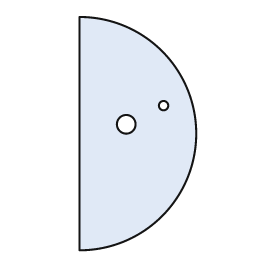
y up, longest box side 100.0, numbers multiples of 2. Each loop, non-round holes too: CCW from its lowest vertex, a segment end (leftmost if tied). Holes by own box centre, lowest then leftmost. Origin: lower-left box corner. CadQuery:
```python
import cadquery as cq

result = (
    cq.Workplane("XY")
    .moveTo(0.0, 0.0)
    .threePointArc((50.0, 50.0), (0.0, 100.0))
    .close()
    .moveTo(20.0, 54.0)
    .circle(4.0)
    .moveTo(36.0, 62.0)
    .circle(2.0)
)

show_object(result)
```